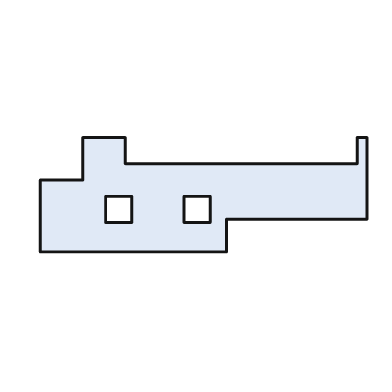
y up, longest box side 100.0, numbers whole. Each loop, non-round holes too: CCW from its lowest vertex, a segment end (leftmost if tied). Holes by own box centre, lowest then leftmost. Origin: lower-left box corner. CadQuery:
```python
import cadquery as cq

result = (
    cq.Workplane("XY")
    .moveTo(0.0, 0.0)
    .lineTo(57.0, 0.0)
    .lineTo(57.0, 10.0)
    .lineTo(100.0, 10.0)
    .lineTo(100.0, 35.0)
    .lineTo(97.0, 35.0)
    .lineTo(97.0, 27.0)
    .lineTo(26.0, 27.0)
    .lineTo(26.0, 35.0)
    .lineTo(13.0, 35.0)
    .lineTo(13.0, 22.0)
    .lineTo(0.0, 22.0)
    .close()
    .moveTo(20.0, 9.0)
    .lineTo(28.0, 9.0)
    .lineTo(28.0, 17.0)
    .lineTo(20.0, 17.0)
    .close()
    .moveTo(44.0, 9.0)
    .lineTo(52.0, 9.0)
    .lineTo(52.0, 17.0)
    .lineTo(44.0, 17.0)
    .close()
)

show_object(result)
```